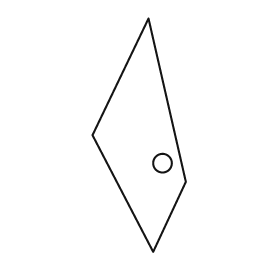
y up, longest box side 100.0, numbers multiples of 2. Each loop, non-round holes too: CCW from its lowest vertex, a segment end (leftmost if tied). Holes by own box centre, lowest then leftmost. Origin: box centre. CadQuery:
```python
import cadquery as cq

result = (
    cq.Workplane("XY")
    .moveTo(6.0, -50.0)
    .lineTo(20.0, -20.0)
    .lineTo(4.0, 50.0)
    .lineTo(-20.0, 0.0)
    .close()
    .moveTo(10.0, -12.0)
    .circle(4.0)
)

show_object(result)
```